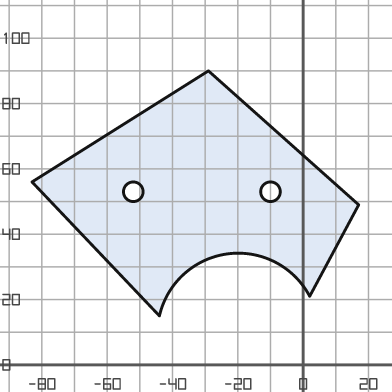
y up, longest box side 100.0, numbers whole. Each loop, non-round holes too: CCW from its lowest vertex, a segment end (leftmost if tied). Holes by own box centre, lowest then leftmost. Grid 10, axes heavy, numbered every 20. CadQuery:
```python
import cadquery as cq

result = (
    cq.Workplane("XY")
    .moveTo(-44.0, 15.0)
    .threePointArc((-23.0, 34.0), (2.0, 21.0))
    .lineTo(17.0, 49.0)
    .lineTo(-29.0, 90.0)
    .lineTo(-83.0, 56.0)
    .close()
    .moveTo(-52.0, 53.0)
    .circle(3.0)
    .moveTo(-10.0, 53.0)
    .circle(3.0)
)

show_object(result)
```